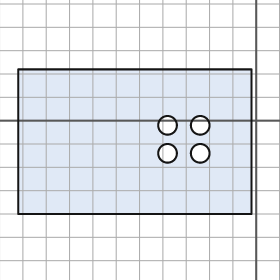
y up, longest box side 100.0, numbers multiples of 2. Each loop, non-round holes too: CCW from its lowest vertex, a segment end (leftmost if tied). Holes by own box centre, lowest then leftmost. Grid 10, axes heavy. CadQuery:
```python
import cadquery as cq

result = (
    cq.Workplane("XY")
    .moveTo(-102.0, -40.0)
    .lineTo(-2.0, -40.0)
    .lineTo(-2.0, 22.0)
    .lineTo(-102.0, 22.0)
    .close()
    .moveTo(-38.0, -14.0)
    .circle(4.0)
    .moveTo(-24.0, -14.0)
    .circle(4.0)
    .moveTo(-38.0, -2.0)
    .circle(4.0)
    .moveTo(-24.0, -2.0)
    .circle(4.0)
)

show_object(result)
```